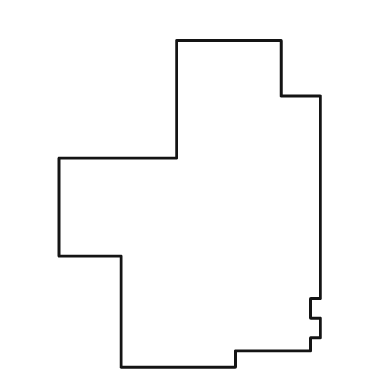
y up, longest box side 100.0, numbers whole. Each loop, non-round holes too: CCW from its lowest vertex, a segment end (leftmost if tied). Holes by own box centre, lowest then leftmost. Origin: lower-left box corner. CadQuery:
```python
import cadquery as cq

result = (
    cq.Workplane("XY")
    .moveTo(19.0, 0.0)
    .lineTo(54.0, 0.0)
    .lineTo(54.0, 5.0)
    .lineTo(77.0, 5.0)
    .lineTo(77.0, 9.0)
    .lineTo(80.0, 9.0)
    .lineTo(80.0, 15.0)
    .lineTo(77.0, 15.0)
    .lineTo(77.0, 21.0)
    .lineTo(80.0, 21.0)
    .lineTo(80.0, 83.0)
    .lineTo(68.0, 83.0)
    .lineTo(68.0, 100.0)
    .lineTo(36.0, 100.0)
    .lineTo(36.0, 64.0)
    .lineTo(0.0, 64.0)
    .lineTo(0.0, 34.0)
    .lineTo(19.0, 34.0)
    .close()
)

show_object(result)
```